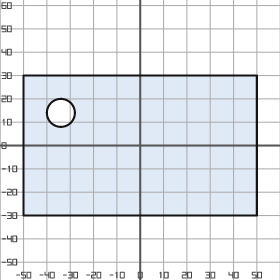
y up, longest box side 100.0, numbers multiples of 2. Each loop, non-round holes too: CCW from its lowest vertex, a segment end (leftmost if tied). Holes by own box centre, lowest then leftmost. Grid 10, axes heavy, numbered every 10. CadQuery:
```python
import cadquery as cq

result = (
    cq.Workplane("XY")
    .moveTo(-50.0, -30.0)
    .lineTo(50.0, -30.0)
    .lineTo(50.0, 30.0)
    .lineTo(-50.0, 30.0)
    .close()
    .moveTo(-34.0, 14.0)
    .circle(6.0)
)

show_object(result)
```